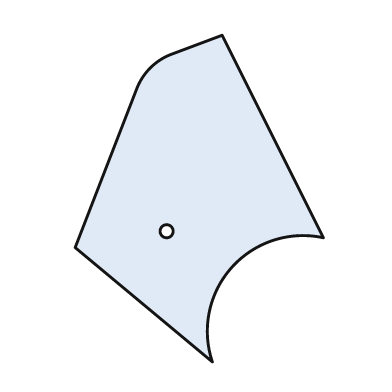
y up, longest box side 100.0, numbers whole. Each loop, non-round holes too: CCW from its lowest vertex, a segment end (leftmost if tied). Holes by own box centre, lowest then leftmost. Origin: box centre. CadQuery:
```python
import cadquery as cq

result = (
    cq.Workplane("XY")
    .moveTo(4.0, -50.0)
    .threePointArc((10.0, -21.0), (38.0, -12.0))
    .lineTo(7.0, 50.0)
    .lineTo(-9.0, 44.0)
    .threePointArc((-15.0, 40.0), (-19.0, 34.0))
    .lineTo(-38.0, -15.0)
    .close()
    .moveTo(-10.0, -10.0)
    .circle(2.0)
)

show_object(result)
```